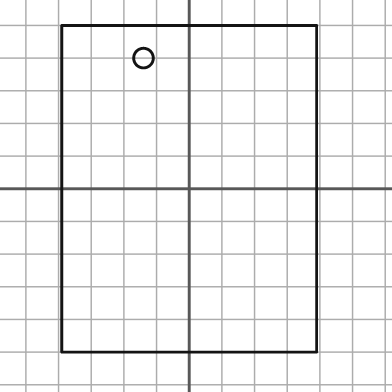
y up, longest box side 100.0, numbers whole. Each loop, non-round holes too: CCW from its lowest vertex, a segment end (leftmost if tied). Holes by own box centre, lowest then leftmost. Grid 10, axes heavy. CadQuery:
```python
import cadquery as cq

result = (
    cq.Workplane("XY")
    .moveTo(-39.0, -50.0)
    .lineTo(39.0, -50.0)
    .lineTo(39.0, 50.0)
    .lineTo(-39.0, 50.0)
    .close()
    .moveTo(-14.0, 40.0)
    .circle(3.0)
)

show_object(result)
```